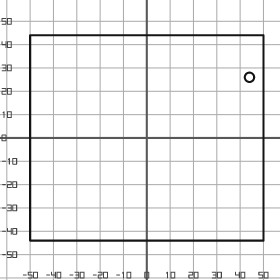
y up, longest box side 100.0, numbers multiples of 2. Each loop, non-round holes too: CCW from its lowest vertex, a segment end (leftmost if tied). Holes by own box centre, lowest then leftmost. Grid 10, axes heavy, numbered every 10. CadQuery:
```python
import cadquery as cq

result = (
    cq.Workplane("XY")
    .moveTo(-50.0, -44.0)
    .lineTo(50.0, -44.0)
    .lineTo(50.0, 44.0)
    .lineTo(-50.0, 44.0)
    .close()
    .moveTo(44.0, 26.0)
    .circle(2.0)
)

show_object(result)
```